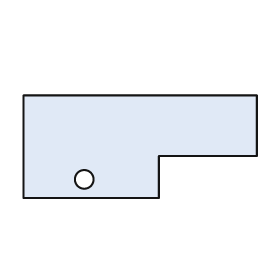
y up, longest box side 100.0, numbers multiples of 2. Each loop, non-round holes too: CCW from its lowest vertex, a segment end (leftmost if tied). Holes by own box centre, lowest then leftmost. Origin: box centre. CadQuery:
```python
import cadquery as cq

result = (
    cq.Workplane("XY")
    .moveTo(-50.0, -22.0)
    .lineTo(8.0, -22.0)
    .lineTo(8.0, -4.0)
    .lineTo(50.0, -4.0)
    .lineTo(50.0, 22.0)
    .lineTo(-50.0, 22.0)
    .close()
    .moveTo(-24.0, -14.0)
    .circle(4.0)
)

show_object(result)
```